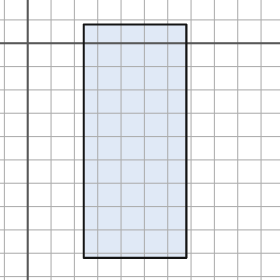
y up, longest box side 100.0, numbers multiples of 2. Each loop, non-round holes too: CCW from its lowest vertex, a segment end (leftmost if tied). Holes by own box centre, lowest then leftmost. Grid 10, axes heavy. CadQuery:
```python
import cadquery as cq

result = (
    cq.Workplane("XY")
    .moveTo(24.0, -92.0)
    .lineTo(68.0, -92.0)
    .lineTo(68.0, 8.0)
    .lineTo(24.0, 8.0)
    .close()
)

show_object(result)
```